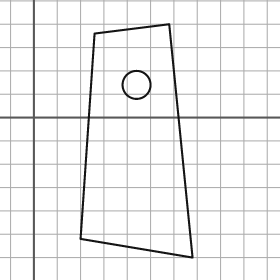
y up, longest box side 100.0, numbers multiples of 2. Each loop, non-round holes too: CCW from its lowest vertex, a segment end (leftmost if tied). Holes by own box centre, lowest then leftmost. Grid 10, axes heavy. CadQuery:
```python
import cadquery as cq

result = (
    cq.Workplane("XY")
    .moveTo(68.0, -60.0)
    .lineTo(58.0, 40.0)
    .lineTo(26.0, 36.0)
    .lineTo(20.0, -52.0)
    .close()
    .moveTo(44.0, 14.0)
    .circle(6.0)
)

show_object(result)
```